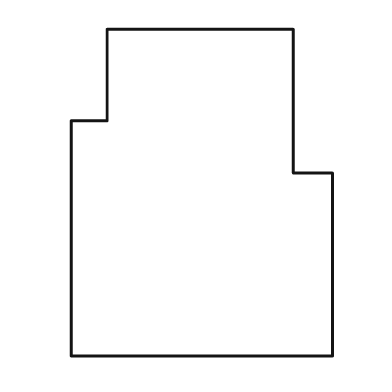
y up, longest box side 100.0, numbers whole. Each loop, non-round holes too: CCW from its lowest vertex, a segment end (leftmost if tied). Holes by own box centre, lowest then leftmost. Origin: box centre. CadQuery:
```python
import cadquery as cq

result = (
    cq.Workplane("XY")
    .moveTo(-40.0, -50.0)
    .lineTo(40.0, -50.0)
    .lineTo(40.0, 6.0)
    .lineTo(28.0, 6.0)
    .lineTo(28.0, 50.0)
    .lineTo(-29.0, 50.0)
    .lineTo(-29.0, 22.0)
    .lineTo(-40.0, 22.0)
    .close()
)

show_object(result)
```